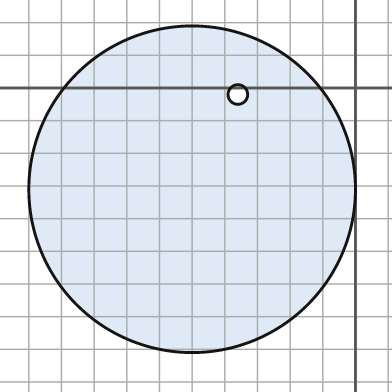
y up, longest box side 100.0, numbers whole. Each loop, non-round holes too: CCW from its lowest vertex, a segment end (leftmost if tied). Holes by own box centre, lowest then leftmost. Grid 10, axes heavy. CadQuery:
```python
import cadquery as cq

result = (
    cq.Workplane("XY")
    .moveTo(-50.0, -31.0)
    .circle(50.0)
    .moveTo(-36.0, -2.0)
    .circle(3.0)
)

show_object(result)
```